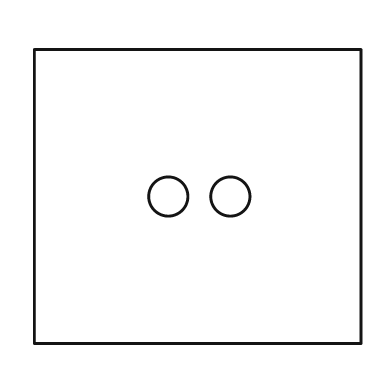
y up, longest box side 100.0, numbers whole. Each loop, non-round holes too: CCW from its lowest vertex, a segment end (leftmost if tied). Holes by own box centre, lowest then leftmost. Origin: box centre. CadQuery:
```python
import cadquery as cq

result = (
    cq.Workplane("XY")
    .moveTo(-50.0, -45.0)
    .lineTo(50.0, -45.0)
    .lineTo(50.0, 45.0)
    .lineTo(-50.0, 45.0)
    .close()
    .moveTo(-9.0, 0.0)
    .circle(6.0)
    .moveTo(10.0, 0.0)
    .circle(6.0)
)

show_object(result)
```